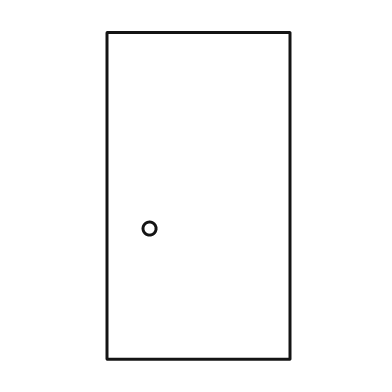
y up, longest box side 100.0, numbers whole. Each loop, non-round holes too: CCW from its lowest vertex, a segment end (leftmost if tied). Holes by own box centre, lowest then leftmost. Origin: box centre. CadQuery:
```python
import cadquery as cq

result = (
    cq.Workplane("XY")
    .moveTo(-28.0, -50.0)
    .lineTo(28.0, -50.0)
    .lineTo(28.0, 50.0)
    .lineTo(-28.0, 50.0)
    .close()
    .moveTo(-15.0, -10.0)
    .circle(2.0)
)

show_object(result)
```